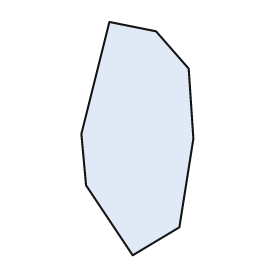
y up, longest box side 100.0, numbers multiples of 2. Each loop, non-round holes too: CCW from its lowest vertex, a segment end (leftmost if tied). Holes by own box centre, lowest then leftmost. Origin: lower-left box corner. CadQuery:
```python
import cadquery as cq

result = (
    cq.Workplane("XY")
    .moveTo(22.0, 0.0)
    .lineTo(42.0, 12.0)
    .lineTo(48.0, 50.0)
    .lineTo(46.0, 80.0)
    .lineTo(32.0, 96.0)
    .lineTo(12.0, 100.0)
    .lineTo(0.0, 52.0)
    .lineTo(2.0, 30.0)
    .close()
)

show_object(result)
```